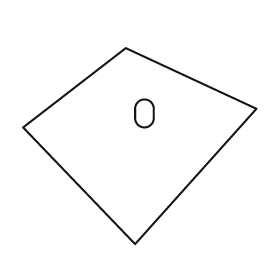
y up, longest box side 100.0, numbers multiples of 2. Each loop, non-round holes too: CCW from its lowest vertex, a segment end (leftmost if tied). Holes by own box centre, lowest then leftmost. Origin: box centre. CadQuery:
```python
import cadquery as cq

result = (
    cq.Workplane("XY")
    .moveTo(-2.0, -42.0)
    .lineTo(50.0, 16.0)
    .lineTo(-6.0, 42.0)
    .lineTo(-50.0, 8.0)
    .close()
    .moveTo(-2.0, 12.0)
    .threePointArc((2.0, 8.0), (6.0, 12.0))
    .lineTo(6.0, 16.0)
    .threePointArc((2.0, 20.0), (-2.0, 16.0))
    .close()
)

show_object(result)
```